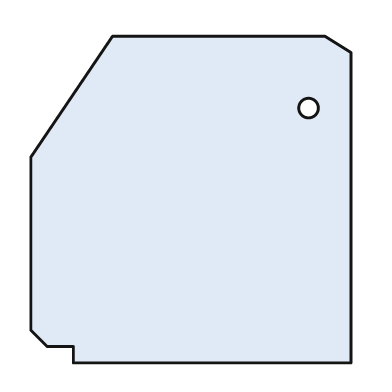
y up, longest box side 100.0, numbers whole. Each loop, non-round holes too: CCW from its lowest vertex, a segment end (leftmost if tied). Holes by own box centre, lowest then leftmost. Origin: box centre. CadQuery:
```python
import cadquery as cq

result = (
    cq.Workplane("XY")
    .moveTo(-36.0, -50.0)
    .lineTo(49.0, -50.0)
    .lineTo(49.0, 45.0)
    .lineTo(41.0, 50.0)
    .lineTo(-24.0, 50.0)
    .lineTo(-49.0, 13.0)
    .lineTo(-49.0, -40.0)
    .lineTo(-44.0, -45.0)
    .lineTo(-36.0, -45.0)
    .close()
    .moveTo(36.0, 28.0)
    .circle(3.0)
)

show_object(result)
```